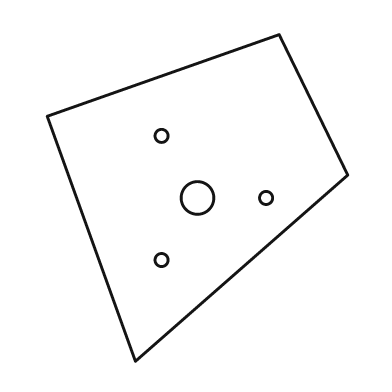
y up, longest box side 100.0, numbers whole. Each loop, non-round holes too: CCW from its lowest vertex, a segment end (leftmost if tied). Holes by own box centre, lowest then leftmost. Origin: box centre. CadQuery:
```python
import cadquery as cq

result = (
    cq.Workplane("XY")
    .moveTo(-19.0, -50.0)
    .lineTo(46.0, 7.0)
    .lineTo(25.0, 50.0)
    .lineTo(-46.0, 25.0)
    .close()
    .moveTo(-11.0, -19.0)
    .circle(2.0)
    .moveTo(0.0, 0.0)
    .circle(5.0)
    .moveTo(21.0, 0.0)
    .circle(2.0)
    .moveTo(-11.0, 19.0)
    .circle(2.0)
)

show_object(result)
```